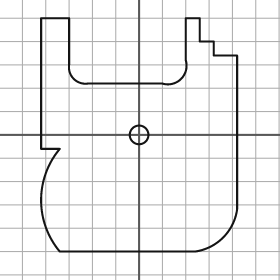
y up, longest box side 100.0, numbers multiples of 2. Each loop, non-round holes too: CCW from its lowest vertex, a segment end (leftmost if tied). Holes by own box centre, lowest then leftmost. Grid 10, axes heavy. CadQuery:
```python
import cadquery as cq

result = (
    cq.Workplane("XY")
    .moveTo(-34.0, -50.0)
    .lineTo(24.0, -50.0)
    .threePointArc((36.0, -44.0), (42.0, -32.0))
    .lineTo(42.0, 34.0)
    .lineTo(32.0, 34.0)
    .lineTo(32.0, 40.0)
    .lineTo(26.0, 40.0)
    .lineTo(26.0, 50.0)
    .lineTo(20.0, 50.0)
    .lineTo(20.0, 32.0)
    .threePointArc((18.0, 24.0), (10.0, 22.0))
    .lineTo(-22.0, 22.0)
    .threePointArc((-28.0, 24.0), (-30.0, 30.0))
    .lineTo(-30.0, 50.0)
    .lineTo(-42.0, 50.0)
    .lineTo(-42.0, -6.0)
    .lineTo(-34.0, -6.0)
    .threePointArc((-42.0, -28.0), (-34.0, -50.0))
    .close()
    .moveTo(0.0, 0.0)
    .circle(4.0)
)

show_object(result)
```